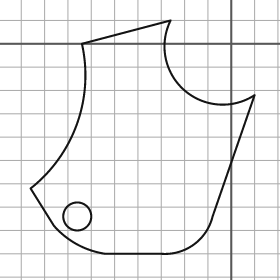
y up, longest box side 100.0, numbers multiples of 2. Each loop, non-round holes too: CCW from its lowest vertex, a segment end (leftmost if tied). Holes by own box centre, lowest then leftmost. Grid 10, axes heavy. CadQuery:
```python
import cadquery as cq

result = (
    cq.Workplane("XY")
    .moveTo(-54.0, -90.0)
    .lineTo(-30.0, -90.0)
    .threePointArc((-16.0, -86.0), (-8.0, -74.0))
    .lineTo(10.0, -22.0)
    .threePointArc((-20.0, -20.0), (-26.0, 10.0))
    .lineTo(-64.0, 0.0)
    .threePointArc((-66.0, -34.0), (-86.0, -62.0))
    .lineTo(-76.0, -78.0)
    .threePointArc((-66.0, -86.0), (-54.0, -90.0))
    .close()
    .moveTo(-66.0, -74.0)
    .circle(6.0)
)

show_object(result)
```